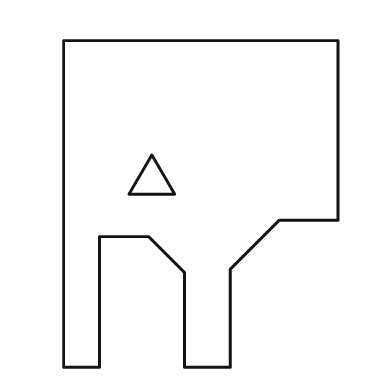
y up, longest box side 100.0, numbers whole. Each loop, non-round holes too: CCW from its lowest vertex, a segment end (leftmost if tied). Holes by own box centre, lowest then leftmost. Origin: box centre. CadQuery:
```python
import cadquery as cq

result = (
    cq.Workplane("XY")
    .moveTo(-42.0, -50.0)
    .lineTo(-31.0, -50.0)
    .lineTo(-31.0, -10.0)
    .lineTo(-16.0, -10.0)
    .lineTo(-5.0, -21.0)
    .lineTo(-5.0, -50.0)
    .lineTo(9.0, -50.0)
    .lineTo(9.0, -20.0)
    .lineTo(24.0, -5.0)
    .lineTo(42.0, -5.0)
    .lineTo(42.0, 50.0)
    .lineTo(-42.0, 50.0)
    .close()
    .moveTo(-22.0, 3.0)
    .lineTo(-8.0, 3.0)
    .lineTo(-15.0, 15.0)
    .close()
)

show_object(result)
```